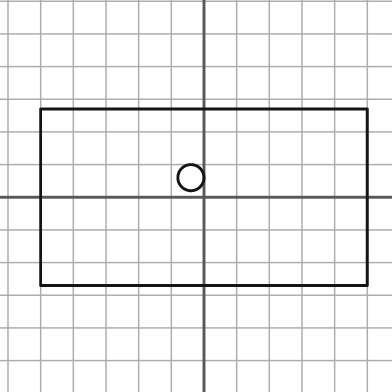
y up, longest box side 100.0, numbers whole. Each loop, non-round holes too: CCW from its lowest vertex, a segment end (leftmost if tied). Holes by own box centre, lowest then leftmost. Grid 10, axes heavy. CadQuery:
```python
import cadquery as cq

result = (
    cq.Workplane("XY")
    .moveTo(-50.0, -27.0)
    .lineTo(50.0, -27.0)
    .lineTo(50.0, 27.0)
    .lineTo(-50.0, 27.0)
    .close()
    .moveTo(-4.0, 6.0)
    .circle(4.0)
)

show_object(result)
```